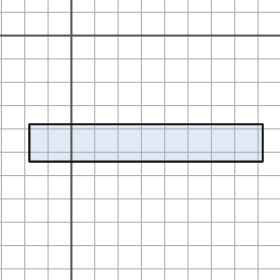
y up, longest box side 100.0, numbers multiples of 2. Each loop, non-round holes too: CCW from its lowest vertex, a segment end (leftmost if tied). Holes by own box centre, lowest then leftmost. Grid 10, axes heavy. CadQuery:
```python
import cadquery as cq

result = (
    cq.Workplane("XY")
    .moveTo(-18.0, -54.0)
    .lineTo(82.0, -54.0)
    .lineTo(82.0, -38.0)
    .lineTo(-18.0, -38.0)
    .close()
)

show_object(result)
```